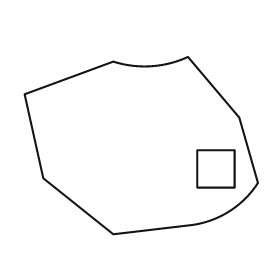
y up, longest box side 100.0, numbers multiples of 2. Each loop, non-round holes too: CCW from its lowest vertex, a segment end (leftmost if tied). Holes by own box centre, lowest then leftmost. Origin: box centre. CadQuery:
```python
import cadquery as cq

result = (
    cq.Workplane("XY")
    .moveTo(-12.0, -38.0)
    .lineTo(22.0, -34.0)
    .threePointArc((38.0, -28.0), (50.0, -16.0))
    .lineTo(42.0, 12.0)
    .lineTo(20.0, 38.0)
    .threePointArc((4.0, 34.0), (-12.0, 36.0))
    .lineTo(-50.0, 22.0)
    .lineTo(-42.0, -14.0)
    .close()
    .moveTo(24.0, -18.0)
    .lineTo(40.0, -18.0)
    .lineTo(40.0, -2.0)
    .lineTo(24.0, -2.0)
    .close()
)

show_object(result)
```